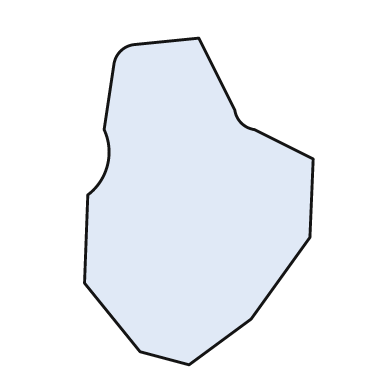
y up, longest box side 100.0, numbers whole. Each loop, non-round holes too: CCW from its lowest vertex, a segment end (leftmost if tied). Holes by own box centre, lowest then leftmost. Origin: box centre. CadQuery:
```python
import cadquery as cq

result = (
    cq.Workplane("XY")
    .moveTo(-3.0, -50.0)
    .lineTo(16.0, -36.0)
    .lineTo(34.0, -11.0)
    .lineTo(35.0, 13.0)
    .lineTo(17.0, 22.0)
    .threePointArc((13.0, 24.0), (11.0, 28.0))
    .lineTo(0.0, 50.0)
    .lineTo(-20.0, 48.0)
    .threePointArc((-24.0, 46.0), (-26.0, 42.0))
    .lineTo(-29.0, 22.0)
    .threePointArc((-28.0, 11.0), (-34.0, 2.0))
    .lineTo(-35.0, -25.0)
    .lineTo(-18.0, -46.0)
    .close()
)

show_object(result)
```